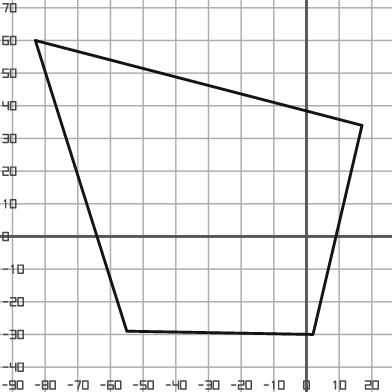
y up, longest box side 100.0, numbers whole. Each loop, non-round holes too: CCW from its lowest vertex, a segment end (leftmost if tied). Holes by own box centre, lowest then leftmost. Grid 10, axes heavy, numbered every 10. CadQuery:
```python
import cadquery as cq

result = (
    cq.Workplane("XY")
    .moveTo(2.0, -30.0)
    .lineTo(17.0, 34.0)
    .lineTo(-83.0, 60.0)
    .lineTo(-55.0, -29.0)
    .close()
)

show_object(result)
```